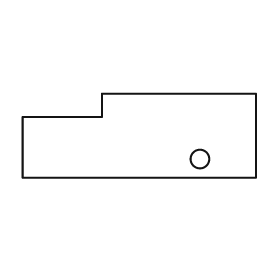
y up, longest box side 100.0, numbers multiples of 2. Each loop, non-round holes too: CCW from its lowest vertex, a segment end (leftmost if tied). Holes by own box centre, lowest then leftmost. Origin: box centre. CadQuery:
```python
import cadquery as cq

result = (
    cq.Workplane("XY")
    .moveTo(-50.0, -18.0)
    .lineTo(50.0, -18.0)
    .lineTo(50.0, 18.0)
    .lineTo(-16.0, 18.0)
    .lineTo(-16.0, 8.0)
    .lineTo(-50.0, 8.0)
    .close()
    .moveTo(26.0, -10.0)
    .circle(4.0)
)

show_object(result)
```